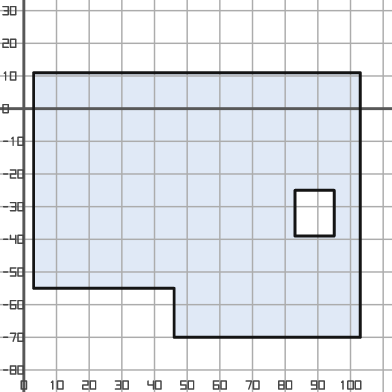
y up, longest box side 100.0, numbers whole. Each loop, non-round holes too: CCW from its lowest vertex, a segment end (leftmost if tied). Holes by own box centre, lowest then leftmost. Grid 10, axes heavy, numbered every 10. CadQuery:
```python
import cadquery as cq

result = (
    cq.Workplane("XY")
    .moveTo(46.0, -70.0)
    .lineTo(103.0, -70.0)
    .lineTo(103.0, 11.0)
    .lineTo(3.0, 11.0)
    .lineTo(3.0, -55.0)
    .lineTo(46.0, -55.0)
    .close()
    .moveTo(83.0, -39.0)
    .lineTo(95.0, -39.0)
    .lineTo(95.0, -25.0)
    .lineTo(83.0, -25.0)
    .close()
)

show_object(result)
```